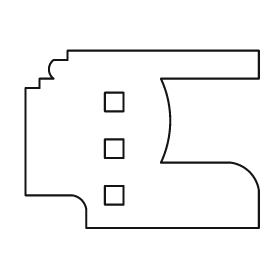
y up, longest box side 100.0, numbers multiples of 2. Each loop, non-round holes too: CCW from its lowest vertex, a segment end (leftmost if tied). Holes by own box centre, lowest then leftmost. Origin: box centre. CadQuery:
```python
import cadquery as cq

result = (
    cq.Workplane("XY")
    .moveTo(-24.0, -38.0)
    .lineTo(50.0, -38.0)
    .lineTo(50.0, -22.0)
    .threePointArc((46.0, -14.0), (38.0, -10.0))
    .lineTo(8.0, -10.0)
    .threePointArc((12.0, 8.0), (8.0, 26.0))
    .lineTo(50.0, 26.0)
    .lineTo(50.0, 38.0)
    .lineTo(-32.0, 38.0)
    .lineTo(-32.0, 34.0)
    .lineTo(-38.0, 34.0)
    .threePointArc((-40.0, 30.0), (-38.0, 26.0))
    .lineTo(-44.0, 26.0)
    .lineTo(-44.0, 22.0)
    .lineTo(-50.0, 22.0)
    .lineTo(-50.0, -24.0)
    .lineTo(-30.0, -24.0)
    .threePointArc((-26.0, -26.0), (-24.0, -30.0))
    .close()
    .moveTo(-16.0, -28.0)
    .lineTo(-8.0, -28.0)
    .lineTo(-8.0, -20.0)
    .lineTo(-16.0, -20.0)
    .close()
    .moveTo(-16.0, -8.0)
    .lineTo(-8.0, -8.0)
    .lineTo(-8.0, 0.0)
    .lineTo(-16.0, 0.0)
    .close()
    .moveTo(-16.0, 12.0)
    .lineTo(-8.0, 12.0)
    .lineTo(-8.0, 20.0)
    .lineTo(-16.0, 20.0)
    .close()
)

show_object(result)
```